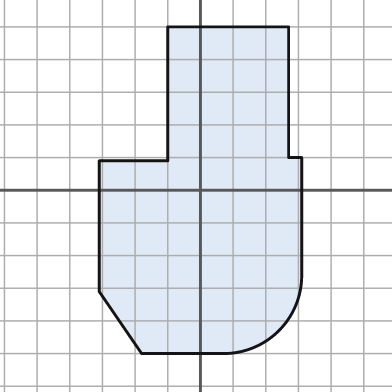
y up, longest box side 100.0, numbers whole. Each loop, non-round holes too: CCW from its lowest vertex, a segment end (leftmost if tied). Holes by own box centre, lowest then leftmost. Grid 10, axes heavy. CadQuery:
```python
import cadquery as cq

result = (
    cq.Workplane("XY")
    .moveTo(-18.0, -50.0)
    .lineTo(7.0, -50.0)
    .threePointArc((24.0, -43.0), (31.0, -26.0))
    .lineTo(31.0, 10.0)
    .lineTo(27.0, 10.0)
    .lineTo(27.0, 50.0)
    .lineTo(-10.0, 50.0)
    .lineTo(-10.0, 9.0)
    .lineTo(-31.0, 9.0)
    .lineTo(-31.0, -31.0)
    .close()
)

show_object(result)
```